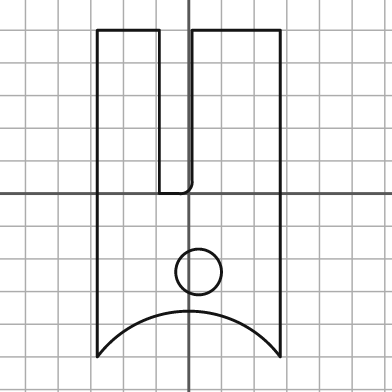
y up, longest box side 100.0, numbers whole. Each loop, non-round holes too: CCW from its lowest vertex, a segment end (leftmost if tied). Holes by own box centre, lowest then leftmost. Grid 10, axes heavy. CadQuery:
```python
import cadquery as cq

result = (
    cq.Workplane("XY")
    .moveTo(-28.0, -50.0)
    .threePointArc((0.0, -36.0), (28.0, -50.0))
    .lineTo(28.0, 50.0)
    .lineTo(1.0, 50.0)
    .lineTo(1.0, 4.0)
    .threePointArc((0.0, 1.0), (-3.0, 0.0))
    .lineTo(-9.0, 0.0)
    .lineTo(-9.0, 50.0)
    .lineTo(-28.0, 50.0)
    .close()
    .moveTo(3.0, -24.0)
    .circle(7.0)
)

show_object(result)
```